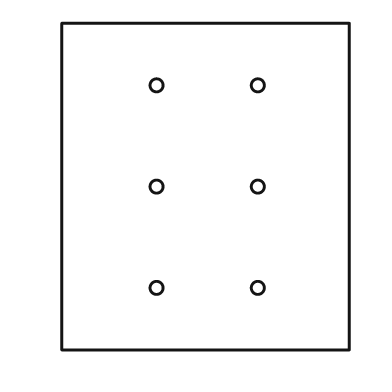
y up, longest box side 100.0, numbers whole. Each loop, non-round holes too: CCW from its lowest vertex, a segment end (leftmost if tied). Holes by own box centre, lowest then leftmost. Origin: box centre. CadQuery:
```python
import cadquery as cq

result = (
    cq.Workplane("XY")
    .moveTo(-44.0, -50.0)
    .lineTo(44.0, -50.0)
    .lineTo(44.0, 50.0)
    .lineTo(-44.0, 50.0)
    .close()
    .moveTo(-15.0, -31.0)
    .circle(2.0)
    .moveTo(16.0, -31.0)
    .circle(2.0)
    .moveTo(-15.0, 0.0)
    .circle(2.0)
    .moveTo(16.0, 0.0)
    .circle(2.0)
    .moveTo(-15.0, 31.0)
    .circle(2.0)
    .moveTo(16.0, 31.0)
    .circle(2.0)
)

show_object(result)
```